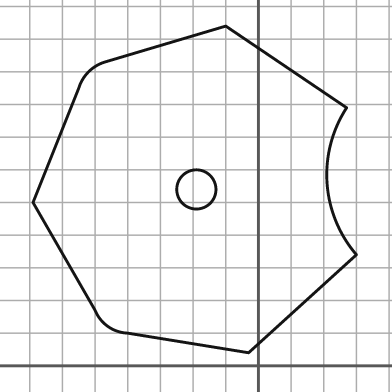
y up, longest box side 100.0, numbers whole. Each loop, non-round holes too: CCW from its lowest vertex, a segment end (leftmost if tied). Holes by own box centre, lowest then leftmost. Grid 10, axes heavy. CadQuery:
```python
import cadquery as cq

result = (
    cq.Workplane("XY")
    .moveTo(-3.0, 4.0)
    .lineTo(30.0, 34.0)
    .threePointArc((21.0, 56.0), (27.0, 79.0))
    .lineTo(-10.0, 104.0)
    .lineTo(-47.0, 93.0)
    .threePointArc((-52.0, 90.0), (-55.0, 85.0))
    .lineTo(-69.0, 50.0)
    .lineTo(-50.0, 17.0)
    .threePointArc((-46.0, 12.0), (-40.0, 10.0))
    .close()
    .moveTo(-19.0, 54.0)
    .circle(6.0)
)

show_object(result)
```